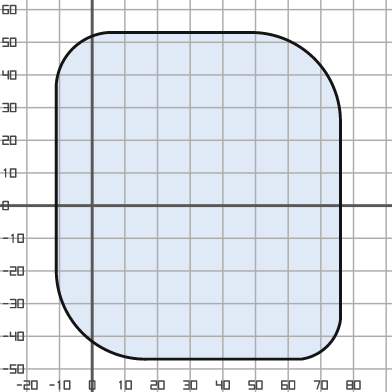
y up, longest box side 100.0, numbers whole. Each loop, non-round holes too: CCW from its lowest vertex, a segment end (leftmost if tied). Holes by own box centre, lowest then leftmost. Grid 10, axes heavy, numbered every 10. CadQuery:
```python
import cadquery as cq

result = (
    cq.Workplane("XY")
    .moveTo(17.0, -47.0)
    .lineTo(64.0, -47.0)
    .threePointArc((72.0, -43.0), (76.0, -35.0))
    .lineTo(76.0, 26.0)
    .threePointArc((68.0, 45.0), (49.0, 53.0))
    .lineTo(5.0, 53.0)
    .threePointArc((-6.0, 48.0), (-11.0, 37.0))
    .lineTo(-11.0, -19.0)
    .threePointArc((-3.0, -39.0), (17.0, -47.0))
    .close()
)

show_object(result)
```